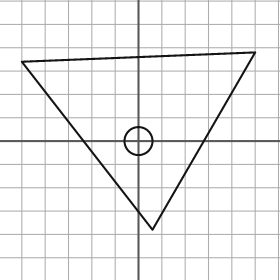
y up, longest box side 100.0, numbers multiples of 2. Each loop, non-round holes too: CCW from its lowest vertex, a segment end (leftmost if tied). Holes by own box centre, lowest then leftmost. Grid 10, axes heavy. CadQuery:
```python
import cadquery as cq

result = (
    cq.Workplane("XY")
    .moveTo(6.0, -38.0)
    .lineTo(50.0, 38.0)
    .lineTo(-50.0, 34.0)
    .close()
    .moveTo(0.0, 0.0)
    .circle(6.0)
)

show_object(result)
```